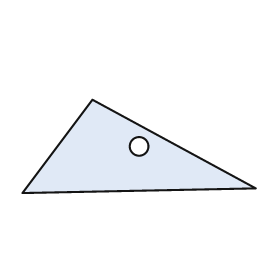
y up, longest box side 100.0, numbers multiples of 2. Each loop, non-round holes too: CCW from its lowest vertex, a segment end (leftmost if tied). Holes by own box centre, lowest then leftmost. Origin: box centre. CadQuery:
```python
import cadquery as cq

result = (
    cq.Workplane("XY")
    .moveTo(-50.0, -20.0)
    .lineTo(50.0, -18.0)
    .lineTo(-20.0, 20.0)
    .close()
    .moveTo(0.0, 0.0)
    .circle(4.0)
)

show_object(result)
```